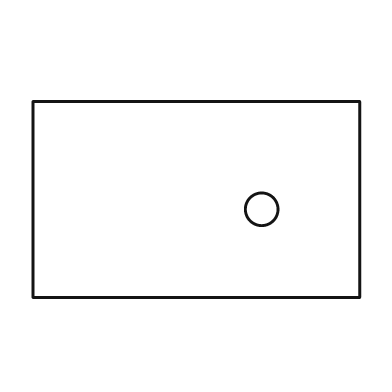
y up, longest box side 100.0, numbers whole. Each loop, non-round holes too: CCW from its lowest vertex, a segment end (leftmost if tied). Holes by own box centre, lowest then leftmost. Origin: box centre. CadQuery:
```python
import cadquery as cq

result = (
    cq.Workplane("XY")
    .moveTo(-50.0, -30.0)
    .lineTo(50.0, -30.0)
    .lineTo(50.0, 30.0)
    .lineTo(-50.0, 30.0)
    .close()
    .moveTo(20.0, -3.0)
    .circle(5.0)
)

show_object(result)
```